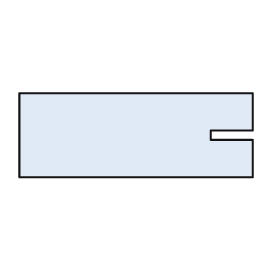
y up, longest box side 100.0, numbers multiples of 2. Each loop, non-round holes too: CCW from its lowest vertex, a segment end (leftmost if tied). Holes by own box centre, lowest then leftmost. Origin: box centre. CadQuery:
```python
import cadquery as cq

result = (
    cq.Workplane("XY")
    .moveTo(-50.0, -18.0)
    .lineTo(50.0, -18.0)
    .lineTo(50.0, -2.0)
    .lineTo(32.0, -2.0)
    .lineTo(32.0, 2.0)
    .lineTo(50.0, 2.0)
    .lineTo(50.0, 18.0)
    .lineTo(-50.0, 18.0)
    .close()
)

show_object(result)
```